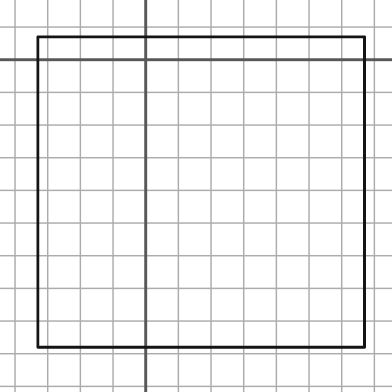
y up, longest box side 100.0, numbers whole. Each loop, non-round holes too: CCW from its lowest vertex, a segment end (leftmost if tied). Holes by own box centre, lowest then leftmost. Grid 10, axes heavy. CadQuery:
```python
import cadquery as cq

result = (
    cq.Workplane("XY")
    .moveTo(-33.0, -88.0)
    .lineTo(67.0, -88.0)
    .lineTo(67.0, 7.0)
    .lineTo(-33.0, 7.0)
    .close()
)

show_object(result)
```